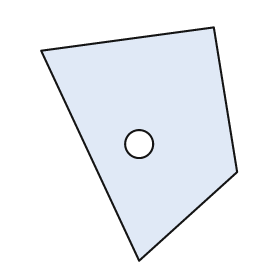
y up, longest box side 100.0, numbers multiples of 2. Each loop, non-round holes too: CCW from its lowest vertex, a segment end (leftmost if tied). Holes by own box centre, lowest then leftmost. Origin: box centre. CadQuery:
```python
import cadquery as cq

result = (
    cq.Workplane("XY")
    .moveTo(0.0, -50.0)
    .lineTo(42.0, -12.0)
    .lineTo(32.0, 50.0)
    .lineTo(-42.0, 40.0)
    .close()
    .moveTo(0.0, 0.0)
    .circle(6.0)
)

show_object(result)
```